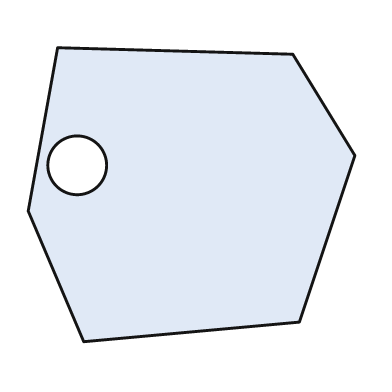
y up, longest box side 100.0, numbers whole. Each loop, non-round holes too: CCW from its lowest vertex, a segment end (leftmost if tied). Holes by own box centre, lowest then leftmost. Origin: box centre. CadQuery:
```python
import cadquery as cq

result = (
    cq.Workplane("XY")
    .moveTo(-33.0, -45.0)
    .lineTo(33.0, -39.0)
    .lineTo(50.0, 12.0)
    .lineTo(31.0, 43.0)
    .lineTo(-41.0, 45.0)
    .lineTo(-50.0, -5.0)
    .close()
    .moveTo(-35.0, 9.0)
    .circle(9.0)
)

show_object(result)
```